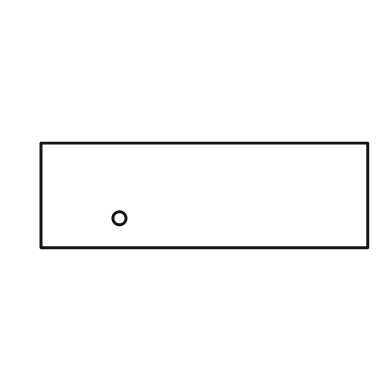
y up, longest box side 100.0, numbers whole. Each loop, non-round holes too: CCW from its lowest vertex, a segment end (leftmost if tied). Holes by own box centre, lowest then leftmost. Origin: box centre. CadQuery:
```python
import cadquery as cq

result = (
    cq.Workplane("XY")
    .moveTo(-50.0, -16.0)
    .lineTo(50.0, -16.0)
    .lineTo(50.0, 16.0)
    .lineTo(-50.0, 16.0)
    .close()
    .moveTo(-26.0, -7.0)
    .circle(2.0)
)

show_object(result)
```